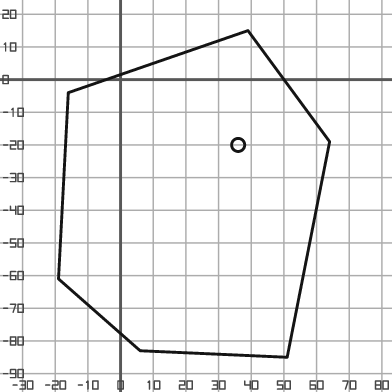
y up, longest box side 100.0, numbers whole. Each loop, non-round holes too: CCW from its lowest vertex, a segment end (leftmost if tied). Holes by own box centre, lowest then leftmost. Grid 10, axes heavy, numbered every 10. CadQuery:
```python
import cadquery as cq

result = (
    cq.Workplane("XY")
    .moveTo(51.0, -85.0)
    .lineTo(64.0, -19.0)
    .lineTo(39.0, 15.0)
    .lineTo(-16.0, -4.0)
    .lineTo(-19.0, -61.0)
    .lineTo(6.0, -83.0)
    .close()
    .moveTo(36.0, -20.0)
    .circle(2.0)
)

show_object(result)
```